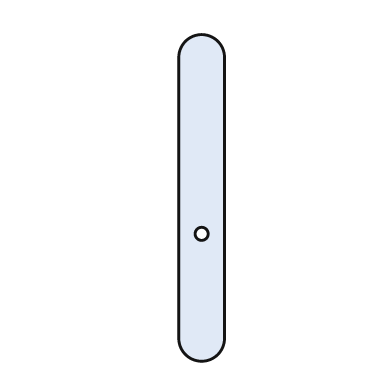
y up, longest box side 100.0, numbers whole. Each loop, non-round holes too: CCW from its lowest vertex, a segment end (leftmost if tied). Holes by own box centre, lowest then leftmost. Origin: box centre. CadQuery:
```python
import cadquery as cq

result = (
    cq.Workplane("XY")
    .moveTo(-7.0, -43.0)
    .threePointArc((0.0, -50.0), (7.0, -43.0))
    .lineTo(7.0, 43.0)
    .threePointArc((0.0, 50.0), (-7.0, 43.0))
    .close()
    .moveTo(0.0, -11.0)
    .circle(2.0)
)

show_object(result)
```